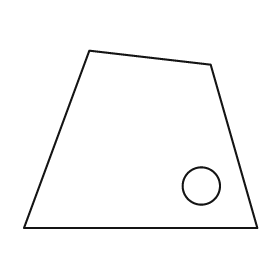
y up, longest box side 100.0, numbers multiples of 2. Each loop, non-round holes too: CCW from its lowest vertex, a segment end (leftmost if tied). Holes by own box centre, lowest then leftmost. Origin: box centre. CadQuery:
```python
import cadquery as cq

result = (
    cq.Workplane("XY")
    .moveTo(-50.0, -38.0)
    .lineTo(50.0, -38.0)
    .lineTo(30.0, 32.0)
    .lineTo(-22.0, 38.0)
    .close()
    .moveTo(26.0, -20.0)
    .circle(8.0)
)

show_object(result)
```